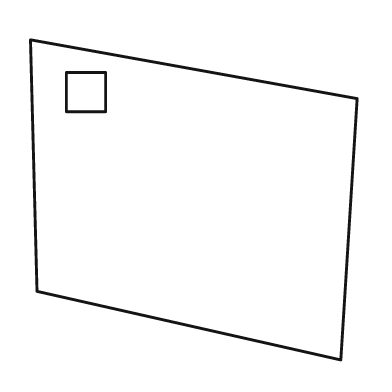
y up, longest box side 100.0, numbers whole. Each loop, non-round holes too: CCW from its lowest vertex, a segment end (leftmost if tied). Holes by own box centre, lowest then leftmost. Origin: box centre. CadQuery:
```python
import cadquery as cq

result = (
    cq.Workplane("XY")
    .moveTo(45.0, -49.0)
    .lineTo(50.0, 31.0)
    .lineTo(-50.0, 49.0)
    .lineTo(-48.0, -28.0)
    .close()
    .moveTo(-39.0, 27.0)
    .lineTo(-27.0, 27.0)
    .lineTo(-27.0, 39.0)
    .lineTo(-39.0, 39.0)
    .close()
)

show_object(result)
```